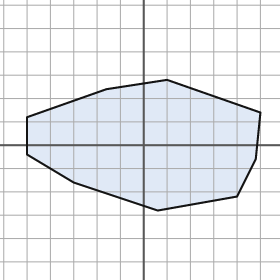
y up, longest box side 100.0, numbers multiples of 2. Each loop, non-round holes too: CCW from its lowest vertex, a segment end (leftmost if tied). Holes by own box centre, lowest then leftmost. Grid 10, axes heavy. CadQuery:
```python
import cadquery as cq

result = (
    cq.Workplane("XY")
    .moveTo(6.0, -28.0)
    .lineTo(40.0, -22.0)
    .lineTo(48.0, -6.0)
    .lineTo(50.0, 14.0)
    .lineTo(10.0, 28.0)
    .lineTo(-16.0, 24.0)
    .lineTo(-50.0, 12.0)
    .lineTo(-50.0, -4.0)
    .lineTo(-30.0, -16.0)
    .close()
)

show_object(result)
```